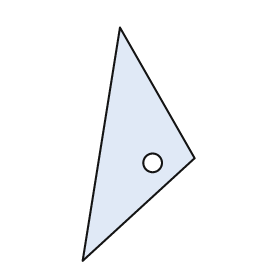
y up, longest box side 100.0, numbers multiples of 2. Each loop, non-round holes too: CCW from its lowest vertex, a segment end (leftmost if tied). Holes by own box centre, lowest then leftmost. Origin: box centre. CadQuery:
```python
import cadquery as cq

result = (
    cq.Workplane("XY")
    .moveTo(-24.0, -50.0)
    .lineTo(24.0, -6.0)
    .lineTo(-8.0, 50.0)
    .close()
    .moveTo(6.0, -8.0)
    .circle(4.0)
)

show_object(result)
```